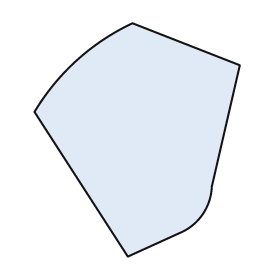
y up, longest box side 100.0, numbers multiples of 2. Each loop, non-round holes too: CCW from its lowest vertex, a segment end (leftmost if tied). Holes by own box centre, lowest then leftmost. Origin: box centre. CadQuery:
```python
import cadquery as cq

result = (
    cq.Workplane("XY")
    .moveTo(-4.0, -50.0)
    .lineTo(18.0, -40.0)
    .threePointArc((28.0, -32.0), (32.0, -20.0))
    .lineTo(44.0, 32.0)
    .lineTo(-2.0, 50.0)
    .threePointArc((-26.0, 34.0), (-44.0, 12.0))
    .close()
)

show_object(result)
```